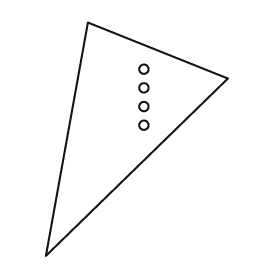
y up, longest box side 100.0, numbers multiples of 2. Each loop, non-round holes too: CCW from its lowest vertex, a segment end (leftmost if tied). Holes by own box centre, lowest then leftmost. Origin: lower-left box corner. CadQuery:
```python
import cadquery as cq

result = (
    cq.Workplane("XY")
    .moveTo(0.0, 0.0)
    .lineTo(78.0, 76.0)
    .lineTo(18.0, 100.0)
    .close()
    .moveTo(42.0, 56.0)
    .circle(2.0)
    .moveTo(42.0, 64.0)
    .circle(2.0)
    .moveTo(42.0, 72.0)
    .circle(2.0)
    .moveTo(42.0, 80.0)
    .circle(2.0)
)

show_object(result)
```